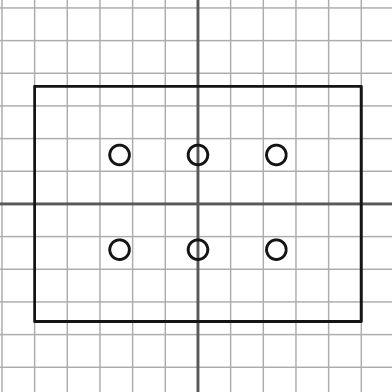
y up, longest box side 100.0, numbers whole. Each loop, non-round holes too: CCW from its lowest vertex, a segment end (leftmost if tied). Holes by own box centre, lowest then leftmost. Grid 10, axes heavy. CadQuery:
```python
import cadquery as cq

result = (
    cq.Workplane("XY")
    .moveTo(-50.0, -36.0)
    .lineTo(50.0, -36.0)
    .lineTo(50.0, 36.0)
    .lineTo(-50.0, 36.0)
    .close()
    .moveTo(-24.0, -14.0)
    .circle(3.0)
    .moveTo(0.0, -14.0)
    .circle(3.0)
    .moveTo(24.0, -14.0)
    .circle(3.0)
    .moveTo(-24.0, 15.0)
    .circle(3.0)
    .moveTo(0.0, 15.0)
    .circle(3.0)
    .moveTo(24.0, 15.0)
    .circle(3.0)
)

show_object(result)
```